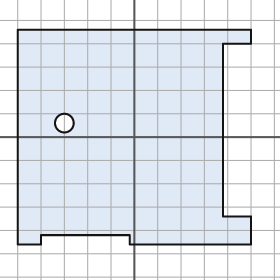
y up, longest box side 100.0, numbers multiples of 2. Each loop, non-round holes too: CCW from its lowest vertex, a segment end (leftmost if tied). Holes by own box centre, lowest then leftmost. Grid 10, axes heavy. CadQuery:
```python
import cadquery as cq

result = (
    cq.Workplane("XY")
    .moveTo(-50.0, -46.0)
    .lineTo(-40.0, -46.0)
    .lineTo(-40.0, -42.0)
    .lineTo(-2.0, -42.0)
    .lineTo(-2.0, -46.0)
    .lineTo(50.0, -46.0)
    .lineTo(50.0, -34.0)
    .lineTo(38.0, -34.0)
    .lineTo(38.0, 40.0)
    .lineTo(50.0, 40.0)
    .lineTo(50.0, 46.0)
    .lineTo(-50.0, 46.0)
    .close()
    .moveTo(-30.0, 6.0)
    .circle(4.0)
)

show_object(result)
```